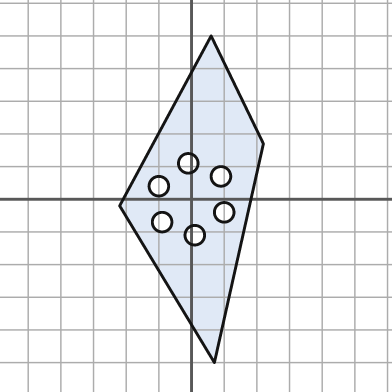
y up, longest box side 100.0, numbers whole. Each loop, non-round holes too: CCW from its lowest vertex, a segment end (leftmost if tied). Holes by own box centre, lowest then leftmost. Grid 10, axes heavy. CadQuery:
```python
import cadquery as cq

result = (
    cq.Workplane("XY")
    .moveTo(7.0, -50.0)
    .lineTo(22.0, 17.0)
    .lineTo(6.0, 50.0)
    .lineTo(-22.0, -2.0)
    .close()
    .moveTo(1.0, -11.0)
    .circle(3.0)
    .moveTo(-9.0, -7.0)
    .circle(3.0)
    .moveTo(10.0, -4.0)
    .circle(3.0)
    .moveTo(-10.0, 4.0)
    .circle(3.0)
    .moveTo(9.0, 7.0)
    .circle(3.0)
    .moveTo(-1.0, 11.0)
    .circle(3.0)
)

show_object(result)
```